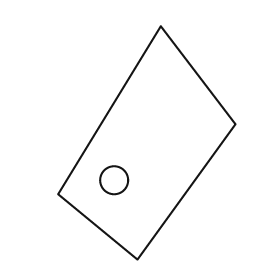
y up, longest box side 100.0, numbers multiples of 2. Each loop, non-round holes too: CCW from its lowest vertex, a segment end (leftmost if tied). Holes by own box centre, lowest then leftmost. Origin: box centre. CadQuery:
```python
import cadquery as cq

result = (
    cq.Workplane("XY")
    .moveTo(-4.0, -50.0)
    .lineTo(38.0, 8.0)
    .lineTo(6.0, 50.0)
    .lineTo(-38.0, -22.0)
    .close()
    .moveTo(-14.0, -16.0)
    .circle(6.0)
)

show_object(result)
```